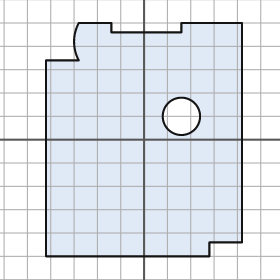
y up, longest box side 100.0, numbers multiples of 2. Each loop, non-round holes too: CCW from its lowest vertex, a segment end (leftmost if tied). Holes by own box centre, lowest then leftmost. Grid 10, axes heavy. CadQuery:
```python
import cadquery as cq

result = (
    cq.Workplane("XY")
    .moveTo(-42.0, -50.0)
    .lineTo(28.0, -50.0)
    .lineTo(28.0, -44.0)
    .lineTo(42.0, -44.0)
    .lineTo(42.0, 50.0)
    .lineTo(16.0, 50.0)
    .lineTo(16.0, 46.0)
    .lineTo(-14.0, 46.0)
    .lineTo(-14.0, 50.0)
    .lineTo(-28.0, 50.0)
    .threePointArc((-30.0, 42.0), (-28.0, 34.0))
    .lineTo(-42.0, 34.0)
    .close()
    .moveTo(16.0, 10.0)
    .circle(8.0)
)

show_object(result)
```